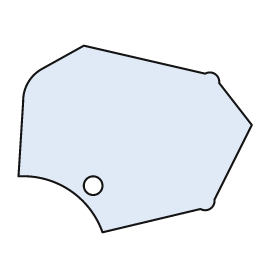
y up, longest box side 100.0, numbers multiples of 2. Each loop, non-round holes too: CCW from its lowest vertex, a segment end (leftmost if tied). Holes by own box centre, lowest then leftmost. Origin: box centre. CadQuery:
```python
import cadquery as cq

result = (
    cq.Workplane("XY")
    .moveTo(-14.0, -40.0)
    .lineTo(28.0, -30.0)
    .threePointArc((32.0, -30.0), (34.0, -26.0))
    .lineTo(50.0, 6.0)
    .lineTo(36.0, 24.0)
    .threePointArc((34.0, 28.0), (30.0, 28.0))
    .lineTo(-22.0, 40.0)
    .lineTo(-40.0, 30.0)
    .threePointArc((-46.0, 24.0), (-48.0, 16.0))
    .lineTo(-50.0, -16.0)
    .threePointArc((-28.0, -22.0), (-14.0, -40.0))
    .close()
    .moveTo(-18.0, -20.0)
    .circle(4.0)
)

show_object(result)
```